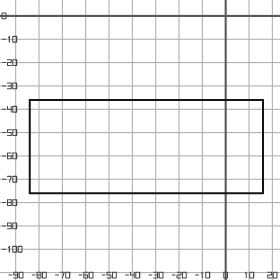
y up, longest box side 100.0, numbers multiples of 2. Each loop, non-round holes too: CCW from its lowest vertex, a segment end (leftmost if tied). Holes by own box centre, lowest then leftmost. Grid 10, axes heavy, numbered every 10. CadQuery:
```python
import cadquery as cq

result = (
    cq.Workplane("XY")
    .moveTo(-84.0, -76.0)
    .lineTo(16.0, -76.0)
    .lineTo(16.0, -36.0)
    .lineTo(-84.0, -36.0)
    .close()
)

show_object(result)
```